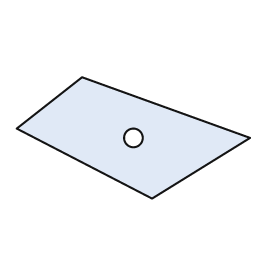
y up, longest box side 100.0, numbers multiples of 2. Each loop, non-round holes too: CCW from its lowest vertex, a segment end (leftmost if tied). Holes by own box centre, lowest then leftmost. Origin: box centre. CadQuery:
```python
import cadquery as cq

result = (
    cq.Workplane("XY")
    .moveTo(8.0, -26.0)
    .lineTo(50.0, 0.0)
    .lineTo(-22.0, 26.0)
    .lineTo(-50.0, 4.0)
    .close()
    .moveTo(0.0, 0.0)
    .circle(4.0)
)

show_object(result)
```